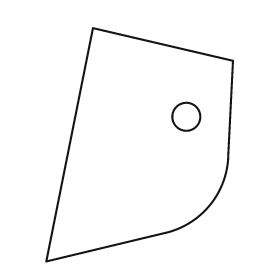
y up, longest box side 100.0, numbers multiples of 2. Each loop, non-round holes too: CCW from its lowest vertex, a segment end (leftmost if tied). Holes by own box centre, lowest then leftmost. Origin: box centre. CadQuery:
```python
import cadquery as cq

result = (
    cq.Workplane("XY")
    .moveTo(-40.0, -50.0)
    .lineTo(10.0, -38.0)
    .threePointArc((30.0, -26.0), (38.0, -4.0))
    .lineTo(40.0, 36.0)
    .lineTo(-20.0, 50.0)
    .close()
    .moveTo(20.0, 12.0)
    .circle(6.0)
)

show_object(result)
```